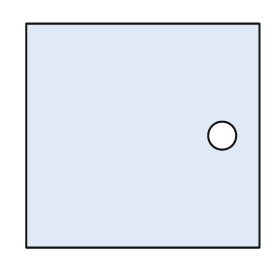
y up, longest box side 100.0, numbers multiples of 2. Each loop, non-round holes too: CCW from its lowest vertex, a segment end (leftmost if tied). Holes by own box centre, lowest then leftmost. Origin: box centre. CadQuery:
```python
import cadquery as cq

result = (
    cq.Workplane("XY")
    .moveTo(-50.0, -48.0)
    .lineTo(50.0, -48.0)
    .lineTo(50.0, 48.0)
    .lineTo(-50.0, 48.0)
    .close()
    .moveTo(34.0, 0.0)
    .circle(6.0)
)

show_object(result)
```